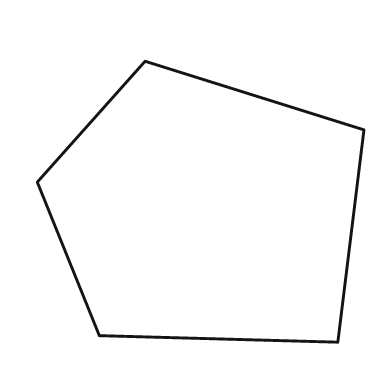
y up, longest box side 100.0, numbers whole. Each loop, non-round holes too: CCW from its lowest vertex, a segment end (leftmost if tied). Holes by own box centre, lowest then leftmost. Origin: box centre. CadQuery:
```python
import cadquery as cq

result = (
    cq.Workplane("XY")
    .moveTo(42.0, -43.0)
    .lineTo(50.0, 22.0)
    .lineTo(-17.0, 43.0)
    .lineTo(-50.0, 6.0)
    .lineTo(-31.0, -41.0)
    .close()
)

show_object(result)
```